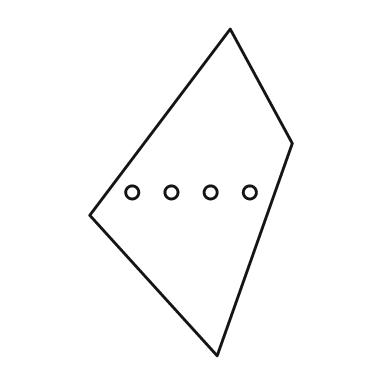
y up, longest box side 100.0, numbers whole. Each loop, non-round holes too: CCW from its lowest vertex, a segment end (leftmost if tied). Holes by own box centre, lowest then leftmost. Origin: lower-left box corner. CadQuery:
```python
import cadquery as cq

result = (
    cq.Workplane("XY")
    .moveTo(39.0, 0.0)
    .lineTo(62.0, 65.0)
    .lineTo(43.0, 100.0)
    .lineTo(0.0, 43.0)
    .close()
    .moveTo(13.0, 50.0)
    .circle(2.0)
    .moveTo(25.0, 50.0)
    .circle(2.0)
    .moveTo(37.0, 50.0)
    .circle(2.0)
    .moveTo(49.0, 50.0)
    .circle(2.0)
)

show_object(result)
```